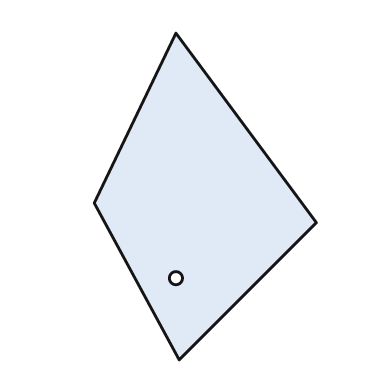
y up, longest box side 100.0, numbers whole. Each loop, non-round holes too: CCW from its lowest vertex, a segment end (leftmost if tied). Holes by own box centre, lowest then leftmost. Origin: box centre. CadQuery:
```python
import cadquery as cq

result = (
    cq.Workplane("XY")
    .moveTo(-8.0, -50.0)
    .lineTo(34.0, -8.0)
    .lineTo(-9.0, 50.0)
    .lineTo(-34.0, -2.0)
    .close()
    .moveTo(-9.0, -25.0)
    .circle(2.0)
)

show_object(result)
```